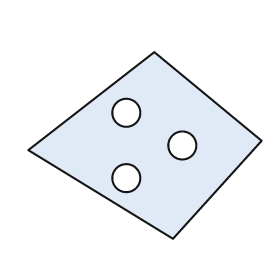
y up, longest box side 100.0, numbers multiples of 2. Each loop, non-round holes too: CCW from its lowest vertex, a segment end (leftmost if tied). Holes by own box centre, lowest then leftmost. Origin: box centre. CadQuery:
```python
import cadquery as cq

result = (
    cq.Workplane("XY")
    .moveTo(12.0, -40.0)
    .lineTo(50.0, 2.0)
    .lineTo(4.0, 40.0)
    .lineTo(-50.0, -2.0)
    .close()
    .moveTo(-8.0, -14.0)
    .circle(6.0)
    .moveTo(16.0, 0.0)
    .circle(6.0)
    .moveTo(-8.0, 14.0)
    .circle(6.0)
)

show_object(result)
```